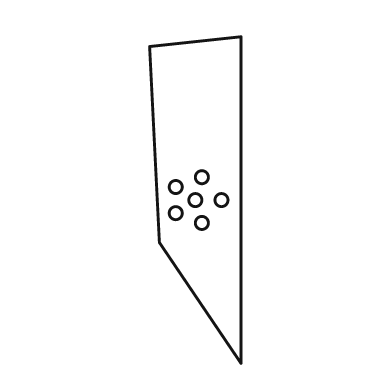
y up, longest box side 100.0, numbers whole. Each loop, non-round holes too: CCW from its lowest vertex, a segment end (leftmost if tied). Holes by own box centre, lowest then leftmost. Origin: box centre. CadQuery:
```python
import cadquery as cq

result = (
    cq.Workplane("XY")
    .moveTo(14.0, -50.0)
    .lineTo(14.0, 50.0)
    .lineTo(-14.0, 47.0)
    .lineTo(-11.0, -13.0)
    .close()
    .moveTo(2.0, -7.0)
    .circle(2.0)
    .moveTo(-6.0, -4.0)
    .circle(2.0)
    .moveTo(0.0, 0.0)
    .circle(2.0)
    .moveTo(8.0, 0.0)
    .circle(2.0)
    .moveTo(-6.0, 4.0)
    .circle(2.0)
    .moveTo(2.0, 7.0)
    .circle(2.0)
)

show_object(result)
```